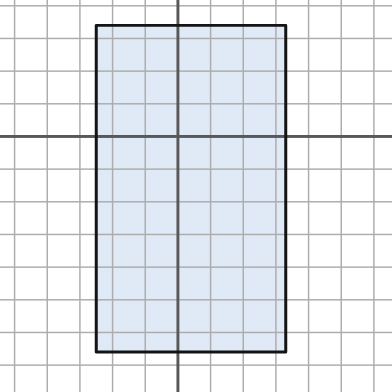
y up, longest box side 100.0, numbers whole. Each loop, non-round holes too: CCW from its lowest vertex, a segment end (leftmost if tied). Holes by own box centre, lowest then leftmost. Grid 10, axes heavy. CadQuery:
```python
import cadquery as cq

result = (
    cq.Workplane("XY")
    .moveTo(-25.0, -66.0)
    .lineTo(33.0, -66.0)
    .lineTo(33.0, 34.0)
    .lineTo(-25.0, 34.0)
    .close()
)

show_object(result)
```